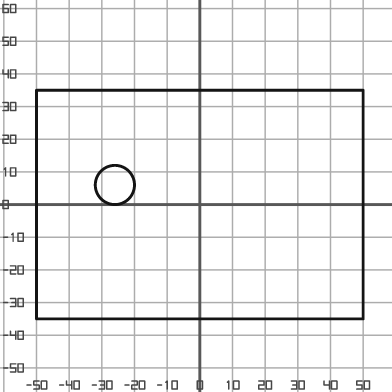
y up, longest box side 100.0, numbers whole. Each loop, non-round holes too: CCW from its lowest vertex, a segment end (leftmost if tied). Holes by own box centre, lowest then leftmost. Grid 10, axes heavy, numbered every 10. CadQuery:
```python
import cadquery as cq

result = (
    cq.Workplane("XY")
    .moveTo(-50.0, -35.0)
    .lineTo(50.0, -35.0)
    .lineTo(50.0, 35.0)
    .lineTo(-50.0, 35.0)
    .close()
    .moveTo(-26.0, 6.0)
    .circle(6.0)
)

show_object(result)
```